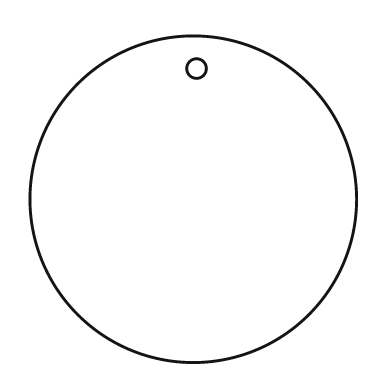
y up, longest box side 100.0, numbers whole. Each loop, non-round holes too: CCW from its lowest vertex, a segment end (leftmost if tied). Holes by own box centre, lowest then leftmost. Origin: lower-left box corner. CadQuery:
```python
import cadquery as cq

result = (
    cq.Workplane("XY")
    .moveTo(50.0, 50.0)
    .circle(50.0)
    .moveTo(51.0, 90.0)
    .circle(3.0)
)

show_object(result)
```